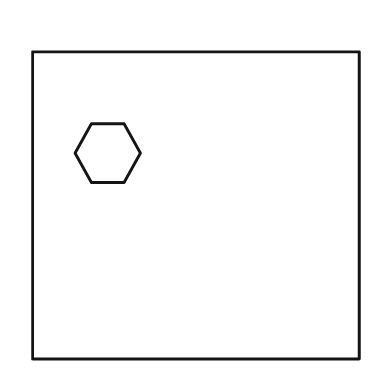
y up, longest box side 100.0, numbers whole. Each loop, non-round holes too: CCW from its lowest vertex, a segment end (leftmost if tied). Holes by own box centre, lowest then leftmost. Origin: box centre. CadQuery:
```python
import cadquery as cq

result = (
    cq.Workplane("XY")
    .moveTo(-50.0, -47.0)
    .lineTo(50.0, -47.0)
    .lineTo(50.0, 47.0)
    .lineTo(-50.0, 47.0)
    .close()
    .moveTo(-32.0, 7.0)
    .lineTo(-22.0, 7.0)
    .lineTo(-17.0, 16.0)
    .lineTo(-22.0, 25.0)
    .lineTo(-32.0, 25.0)
    .lineTo(-37.0, 16.0)
    .close()
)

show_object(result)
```